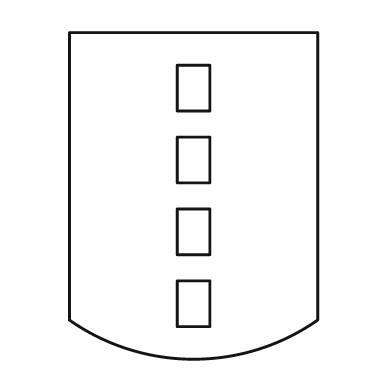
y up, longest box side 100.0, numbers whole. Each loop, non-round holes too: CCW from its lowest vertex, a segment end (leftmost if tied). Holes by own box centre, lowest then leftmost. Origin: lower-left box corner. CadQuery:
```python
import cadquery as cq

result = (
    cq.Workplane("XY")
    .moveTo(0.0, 12.0)
    .threePointArc((38.0, 0.0), (76.0, 12.0))
    .lineTo(76.0, 100.0)
    .lineTo(0.0, 100.0)
    .close()
    .moveTo(33.0, 10.0)
    .lineTo(43.0, 10.0)
    .lineTo(43.0, 24.0)
    .lineTo(33.0, 24.0)
    .close()
    .moveTo(33.0, 32.0)
    .lineTo(43.0, 32.0)
    .lineTo(43.0, 46.0)
    .lineTo(33.0, 46.0)
    .close()
    .moveTo(33.0, 54.0)
    .lineTo(43.0, 54.0)
    .lineTo(43.0, 68.0)
    .lineTo(33.0, 68.0)
    .close()
    .moveTo(33.0, 76.0)
    .lineTo(43.0, 76.0)
    .lineTo(43.0, 90.0)
    .lineTo(33.0, 90.0)
    .close()
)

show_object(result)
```